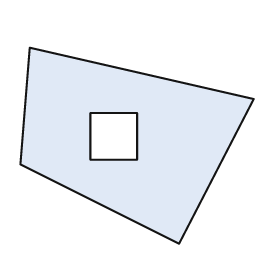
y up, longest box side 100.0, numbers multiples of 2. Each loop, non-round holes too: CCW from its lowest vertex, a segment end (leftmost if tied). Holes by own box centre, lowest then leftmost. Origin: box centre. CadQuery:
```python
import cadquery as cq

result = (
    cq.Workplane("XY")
    .moveTo(18.0, -42.0)
    .lineTo(50.0, 20.0)
    .lineTo(-46.0, 42.0)
    .lineTo(-50.0, -8.0)
    .close()
    .moveTo(-20.0, -6.0)
    .lineTo(0.0, -6.0)
    .lineTo(0.0, 14.0)
    .lineTo(-20.0, 14.0)
    .close()
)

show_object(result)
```